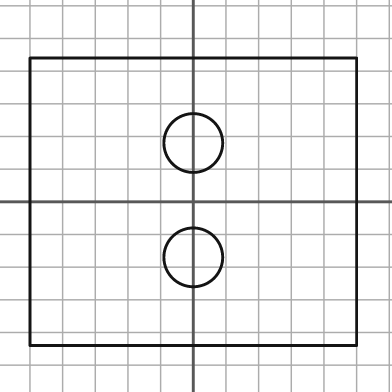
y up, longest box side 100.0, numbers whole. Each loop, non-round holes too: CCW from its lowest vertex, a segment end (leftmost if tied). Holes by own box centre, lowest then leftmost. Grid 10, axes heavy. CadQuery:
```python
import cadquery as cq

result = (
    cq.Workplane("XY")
    .moveTo(-50.0, -44.0)
    .lineTo(50.0, -44.0)
    .lineTo(50.0, 44.0)
    .lineTo(-50.0, 44.0)
    .close()
    .moveTo(0.0, -17.0)
    .circle(9.0)
    .moveTo(0.0, 18.0)
    .circle(9.0)
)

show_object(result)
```